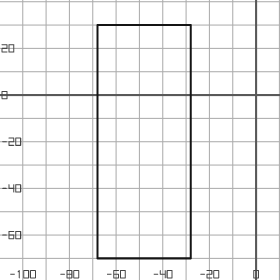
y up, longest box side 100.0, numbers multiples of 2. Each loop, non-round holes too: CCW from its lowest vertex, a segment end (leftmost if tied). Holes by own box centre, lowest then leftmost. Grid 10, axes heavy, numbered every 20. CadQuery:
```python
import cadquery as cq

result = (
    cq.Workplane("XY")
    .moveTo(-68.0, -70.0)
    .lineTo(-28.0, -70.0)
    .lineTo(-28.0, 30.0)
    .lineTo(-68.0, 30.0)
    .close()
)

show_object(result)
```